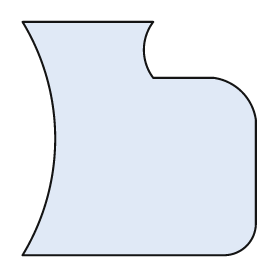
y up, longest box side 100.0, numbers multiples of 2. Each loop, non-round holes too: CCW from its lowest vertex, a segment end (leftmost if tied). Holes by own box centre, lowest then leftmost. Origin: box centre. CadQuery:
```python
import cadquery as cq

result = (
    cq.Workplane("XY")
    .moveTo(-50.0, -50.0)
    .lineTo(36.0, -50.0)
    .threePointArc((46.0, -46.0), (50.0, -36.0))
    .lineTo(50.0, 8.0)
    .threePointArc((44.0, 20.0), (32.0, 26.0))
    .lineTo(6.0, 26.0)
    .threePointArc((2.0, 38.0), (6.0, 50.0))
    .lineTo(-50.0, 50.0)
    .threePointArc((-36.0, 0.0), (-50.0, -50.0))
    .close()
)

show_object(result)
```